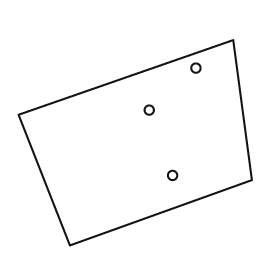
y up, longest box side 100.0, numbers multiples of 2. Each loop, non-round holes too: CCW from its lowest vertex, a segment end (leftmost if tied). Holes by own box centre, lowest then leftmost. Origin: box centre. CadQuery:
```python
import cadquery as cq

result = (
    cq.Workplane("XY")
    .moveTo(-28.0, -44.0)
    .lineTo(50.0, -16.0)
    .lineTo(42.0, 44.0)
    .lineTo(-50.0, 12.0)
    .close()
    .moveTo(16.0, -14.0)
    .circle(2.0)
    .moveTo(6.0, 14.0)
    .circle(2.0)
    .moveTo(26.0, 32.0)
    .circle(2.0)
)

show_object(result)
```